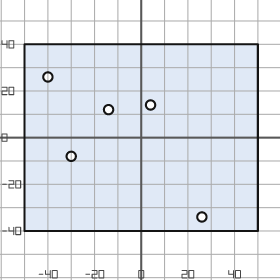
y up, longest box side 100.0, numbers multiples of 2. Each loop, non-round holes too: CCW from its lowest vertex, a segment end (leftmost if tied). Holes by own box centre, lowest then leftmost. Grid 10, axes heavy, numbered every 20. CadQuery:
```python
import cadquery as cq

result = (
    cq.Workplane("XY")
    .moveTo(-50.0, -40.0)
    .lineTo(50.0, -40.0)
    .lineTo(50.0, 40.0)
    .lineTo(-50.0, 40.0)
    .close()
    .moveTo(26.0, -34.0)
    .circle(2.0)
    .moveTo(-30.0, -8.0)
    .circle(2.0)
    .moveTo(-14.0, 12.0)
    .circle(2.0)
    .moveTo(4.0, 14.0)
    .circle(2.0)
    .moveTo(-40.0, 26.0)
    .circle(2.0)
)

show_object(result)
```